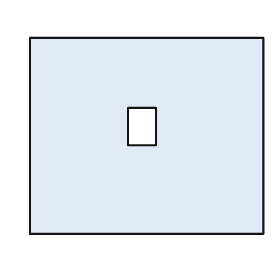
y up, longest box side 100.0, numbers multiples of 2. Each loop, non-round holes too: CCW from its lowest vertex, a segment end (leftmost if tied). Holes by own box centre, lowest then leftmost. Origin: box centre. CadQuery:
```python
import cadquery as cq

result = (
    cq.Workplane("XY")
    .moveTo(-50.0, -42.0)
    .lineTo(50.0, -42.0)
    .lineTo(50.0, 42.0)
    .lineTo(-50.0, 42.0)
    .close()
    .moveTo(-8.0, -4.0)
    .lineTo(4.0, -4.0)
    .lineTo(4.0, 12.0)
    .lineTo(-8.0, 12.0)
    .close()
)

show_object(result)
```